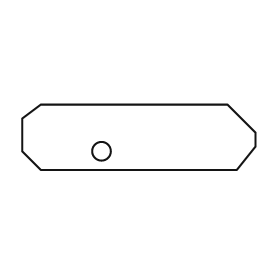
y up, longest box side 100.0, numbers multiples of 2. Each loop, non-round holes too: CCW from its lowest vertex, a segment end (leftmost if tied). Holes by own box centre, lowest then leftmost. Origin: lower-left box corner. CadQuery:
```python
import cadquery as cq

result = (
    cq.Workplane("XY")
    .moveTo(8.0, 0.0)
    .lineTo(92.0, 0.0)
    .lineTo(100.0, 10.0)
    .lineTo(100.0, 16.0)
    .lineTo(88.0, 28.0)
    .lineTo(8.0, 28.0)
    .lineTo(0.0, 22.0)
    .lineTo(0.0, 8.0)
    .close()
    .moveTo(34.0, 8.0)
    .circle(4.0)
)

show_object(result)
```